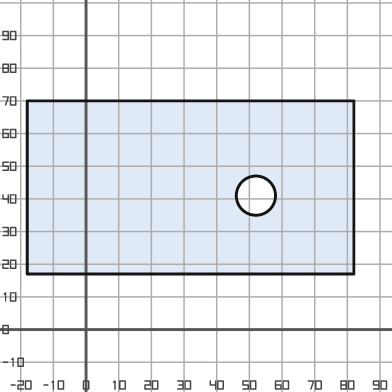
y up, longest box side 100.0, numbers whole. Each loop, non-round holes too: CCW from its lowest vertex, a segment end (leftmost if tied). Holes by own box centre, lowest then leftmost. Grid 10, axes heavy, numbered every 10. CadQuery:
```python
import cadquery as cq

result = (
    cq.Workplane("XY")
    .moveTo(-18.0, 17.0)
    .lineTo(82.0, 17.0)
    .lineTo(82.0, 70.0)
    .lineTo(-18.0, 70.0)
    .close()
    .moveTo(52.0, 41.0)
    .circle(6.0)
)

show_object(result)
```